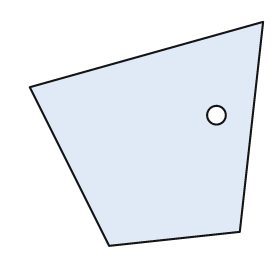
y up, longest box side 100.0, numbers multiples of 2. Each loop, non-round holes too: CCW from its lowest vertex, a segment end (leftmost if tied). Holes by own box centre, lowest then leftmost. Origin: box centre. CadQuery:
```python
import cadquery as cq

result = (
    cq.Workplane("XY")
    .moveTo(-16.0, -48.0)
    .lineTo(40.0, -42.0)
    .lineTo(50.0, 48.0)
    .lineTo(-50.0, 20.0)
    .close()
    .moveTo(30.0, 8.0)
    .circle(4.0)
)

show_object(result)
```